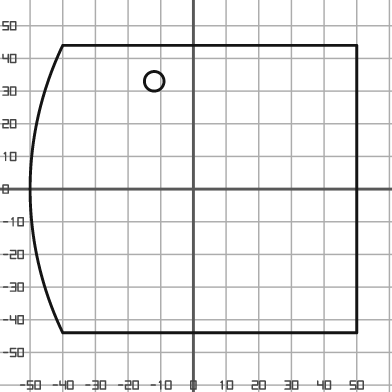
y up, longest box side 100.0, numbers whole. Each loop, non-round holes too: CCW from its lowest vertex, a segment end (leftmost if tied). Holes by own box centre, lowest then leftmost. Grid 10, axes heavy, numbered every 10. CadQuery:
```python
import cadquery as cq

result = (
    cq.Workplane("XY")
    .moveTo(-40.0, -44.0)
    .lineTo(50.0, -44.0)
    .lineTo(50.0, 44.0)
    .lineTo(-40.0, 44.0)
    .threePointArc((-50.0, 0.0), (-40.0, -44.0))
    .close()
    .moveTo(-12.0, 33.0)
    .circle(3.0)
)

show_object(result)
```